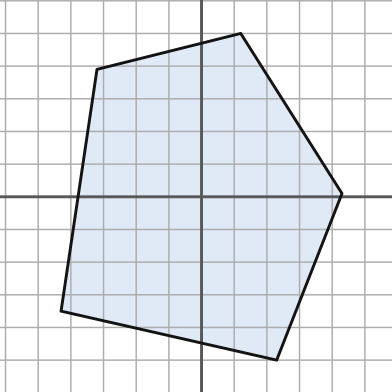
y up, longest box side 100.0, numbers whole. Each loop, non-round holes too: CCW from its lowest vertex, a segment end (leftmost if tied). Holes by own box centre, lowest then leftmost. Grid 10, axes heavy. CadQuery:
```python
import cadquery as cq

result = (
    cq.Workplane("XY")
    .moveTo(23.0, -50.0)
    .lineTo(43.0, 1.0)
    .lineTo(12.0, 50.0)
    .lineTo(-32.0, 39.0)
    .lineTo(-43.0, -35.0)
    .close()
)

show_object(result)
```